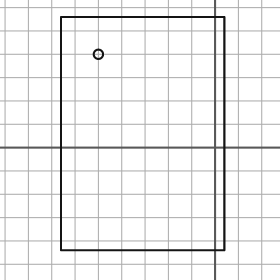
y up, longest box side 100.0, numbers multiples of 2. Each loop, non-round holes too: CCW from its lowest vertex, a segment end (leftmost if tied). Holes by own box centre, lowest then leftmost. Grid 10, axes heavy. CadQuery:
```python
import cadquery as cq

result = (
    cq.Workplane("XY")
    .moveTo(-66.0, -44.0)
    .lineTo(4.0, -44.0)
    .lineTo(4.0, 56.0)
    .lineTo(-66.0, 56.0)
    .close()
    .moveTo(-50.0, 40.0)
    .circle(2.0)
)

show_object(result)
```